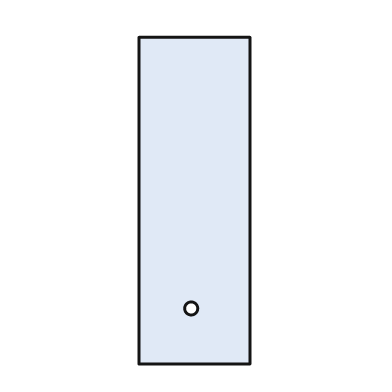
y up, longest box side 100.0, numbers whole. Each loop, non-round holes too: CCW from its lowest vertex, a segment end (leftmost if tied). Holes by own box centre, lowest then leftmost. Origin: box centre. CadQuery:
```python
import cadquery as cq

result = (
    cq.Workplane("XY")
    .moveTo(-17.0, -50.0)
    .lineTo(17.0, -50.0)
    .lineTo(17.0, 50.0)
    .lineTo(-17.0, 50.0)
    .close()
    .moveTo(-1.0, -33.0)
    .circle(2.0)
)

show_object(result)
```